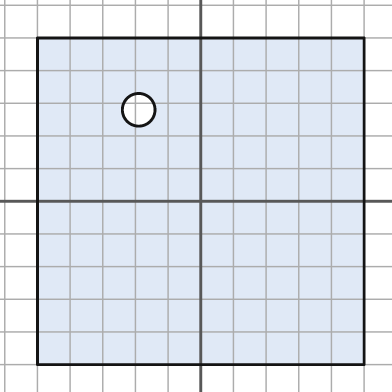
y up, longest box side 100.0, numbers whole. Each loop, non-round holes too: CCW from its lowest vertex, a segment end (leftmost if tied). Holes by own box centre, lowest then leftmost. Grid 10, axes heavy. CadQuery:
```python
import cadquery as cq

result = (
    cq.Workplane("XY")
    .moveTo(-50.0, -50.0)
    .lineTo(50.0, -50.0)
    .lineTo(50.0, 50.0)
    .lineTo(-50.0, 50.0)
    .close()
    .moveTo(-19.0, 28.0)
    .circle(5.0)
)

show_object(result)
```